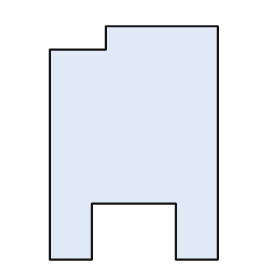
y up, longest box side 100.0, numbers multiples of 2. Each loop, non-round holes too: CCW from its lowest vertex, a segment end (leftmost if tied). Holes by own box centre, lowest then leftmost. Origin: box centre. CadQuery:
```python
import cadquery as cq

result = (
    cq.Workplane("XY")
    .moveTo(-36.0, -50.0)
    .lineTo(-18.0, -50.0)
    .lineTo(-18.0, -26.0)
    .lineTo(18.0, -26.0)
    .lineTo(18.0, -50.0)
    .lineTo(36.0, -50.0)
    .lineTo(36.0, 50.0)
    .lineTo(-12.0, 50.0)
    .lineTo(-12.0, 40.0)
    .lineTo(-36.0, 40.0)
    .close()
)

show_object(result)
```